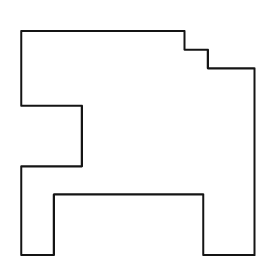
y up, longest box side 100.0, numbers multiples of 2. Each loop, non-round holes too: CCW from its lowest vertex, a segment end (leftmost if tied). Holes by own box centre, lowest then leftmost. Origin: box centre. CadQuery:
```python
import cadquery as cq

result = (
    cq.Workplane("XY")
    .moveTo(-50.0, -48.0)
    .lineTo(-36.0, -48.0)
    .lineTo(-36.0, -22.0)
    .lineTo(28.0, -22.0)
    .lineTo(28.0, -48.0)
    .lineTo(50.0, -48.0)
    .lineTo(50.0, 32.0)
    .lineTo(30.0, 32.0)
    .lineTo(30.0, 40.0)
    .lineTo(20.0, 40.0)
    .lineTo(20.0, 48.0)
    .lineTo(-50.0, 48.0)
    .lineTo(-50.0, 16.0)
    .lineTo(-24.0, 16.0)
    .lineTo(-24.0, -10.0)
    .lineTo(-50.0, -10.0)
    .close()
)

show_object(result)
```